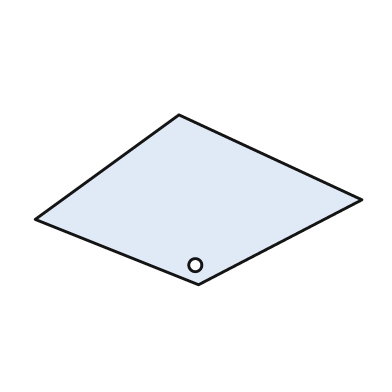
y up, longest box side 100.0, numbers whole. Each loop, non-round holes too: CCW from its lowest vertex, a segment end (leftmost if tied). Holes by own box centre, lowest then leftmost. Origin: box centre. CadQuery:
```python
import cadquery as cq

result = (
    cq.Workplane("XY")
    .moveTo(0.0, -26.0)
    .lineTo(50.0, 0.0)
    .lineTo(-6.0, 26.0)
    .lineTo(-50.0, -6.0)
    .close()
    .moveTo(-1.0, -20.0)
    .circle(2.0)
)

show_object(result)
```